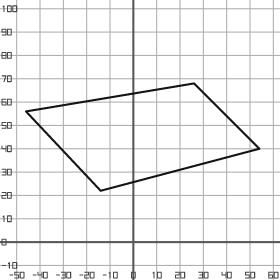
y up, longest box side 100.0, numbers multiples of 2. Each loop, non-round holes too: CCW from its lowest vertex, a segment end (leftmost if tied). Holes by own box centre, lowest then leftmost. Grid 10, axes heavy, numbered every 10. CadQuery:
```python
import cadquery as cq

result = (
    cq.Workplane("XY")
    .moveTo(-14.0, 22.0)
    .lineTo(54.0, 40.0)
    .lineTo(26.0, 68.0)
    .lineTo(-46.0, 56.0)
    .close()
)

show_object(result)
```